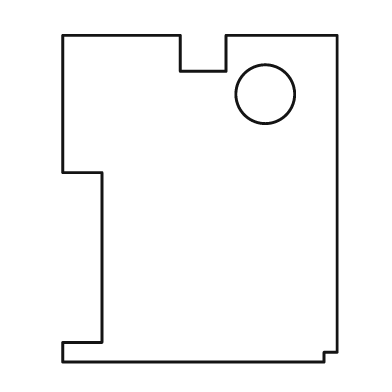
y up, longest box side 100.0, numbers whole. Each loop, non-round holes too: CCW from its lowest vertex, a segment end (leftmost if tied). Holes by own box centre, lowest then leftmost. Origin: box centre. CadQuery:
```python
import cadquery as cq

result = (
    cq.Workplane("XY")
    .moveTo(-42.0, -50.0)
    .lineTo(38.0, -50.0)
    .lineTo(38.0, -47.0)
    .lineTo(42.0, -47.0)
    .lineTo(42.0, 50.0)
    .lineTo(8.0, 50.0)
    .lineTo(8.0, 39.0)
    .lineTo(-6.0, 39.0)
    .lineTo(-6.0, 50.0)
    .lineTo(-42.0, 50.0)
    .lineTo(-42.0, 8.0)
    .lineTo(-30.0, 8.0)
    .lineTo(-30.0, -44.0)
    .lineTo(-42.0, -44.0)
    .close()
    .moveTo(20.0, 32.0)
    .circle(9.0)
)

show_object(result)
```